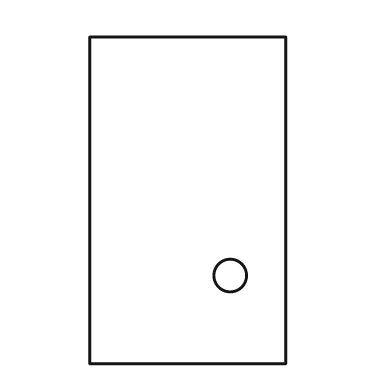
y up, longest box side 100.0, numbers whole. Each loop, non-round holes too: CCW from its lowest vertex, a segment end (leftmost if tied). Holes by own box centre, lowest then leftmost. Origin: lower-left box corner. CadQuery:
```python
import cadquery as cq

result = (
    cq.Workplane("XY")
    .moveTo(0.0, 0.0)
    .lineTo(60.0, 0.0)
    .lineTo(60.0, 100.0)
    .lineTo(0.0, 100.0)
    .close()
    .moveTo(43.0, 27.0)
    .circle(5.0)
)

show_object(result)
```